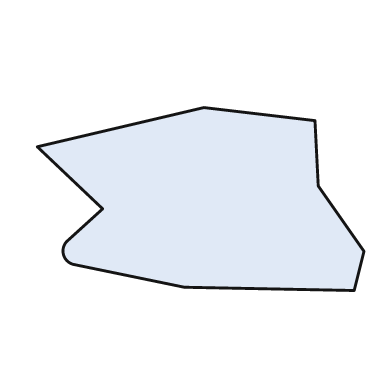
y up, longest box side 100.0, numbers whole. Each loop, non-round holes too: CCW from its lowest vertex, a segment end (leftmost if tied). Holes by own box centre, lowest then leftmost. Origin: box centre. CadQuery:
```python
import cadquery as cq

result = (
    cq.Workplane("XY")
    .moveTo(47.0, -28.0)
    .lineTo(50.0, -16.0)
    .lineTo(36.0, 4.0)
    .lineTo(35.0, 24.0)
    .lineTo(1.0, 28.0)
    .lineTo(-50.0, 16.0)
    .lineTo(-30.0, -3.0)
    .lineTo(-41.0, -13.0)
    .threePointArc((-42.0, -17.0), (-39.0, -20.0))
    .lineTo(-5.0, -27.0)
    .close()
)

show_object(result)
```